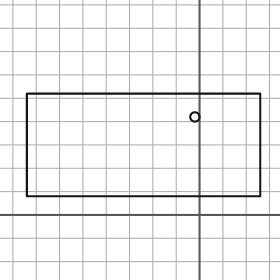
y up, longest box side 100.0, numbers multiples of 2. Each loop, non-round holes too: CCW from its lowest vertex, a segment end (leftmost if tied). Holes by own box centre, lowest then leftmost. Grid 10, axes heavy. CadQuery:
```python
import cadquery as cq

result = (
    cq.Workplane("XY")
    .moveTo(-74.0, 8.0)
    .lineTo(26.0, 8.0)
    .lineTo(26.0, 52.0)
    .lineTo(-74.0, 52.0)
    .close()
    .moveTo(-2.0, 42.0)
    .circle(2.0)
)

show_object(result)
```